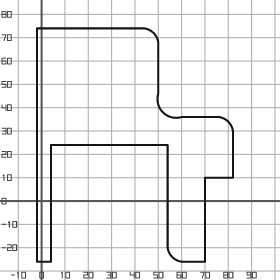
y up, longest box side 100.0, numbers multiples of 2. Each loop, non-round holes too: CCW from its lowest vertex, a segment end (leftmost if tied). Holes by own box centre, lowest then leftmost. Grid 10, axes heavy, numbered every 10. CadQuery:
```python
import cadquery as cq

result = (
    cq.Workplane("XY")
    .moveTo(-2.0, -26.0)
    .lineTo(4.0, -26.0)
    .lineTo(4.0, 24.0)
    .lineTo(54.0, 24.0)
    .lineTo(54.0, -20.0)
    .threePointArc((56.0, -24.0), (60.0, -26.0))
    .lineTo(70.0, -26.0)
    .lineTo(70.0, 10.0)
    .lineTo(82.0, 10.0)
    .lineTo(82.0, 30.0)
    .threePointArc((80.0, 34.0), (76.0, 36.0))
    .lineTo(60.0, 36.0)
    .threePointArc((52.0, 38.0), (50.0, 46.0))
    .lineTo(50.0, 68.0)
    .threePointArc((48.0, 72.0), (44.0, 74.0))
    .lineTo(-2.0, 74.0)
    .close()
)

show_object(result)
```